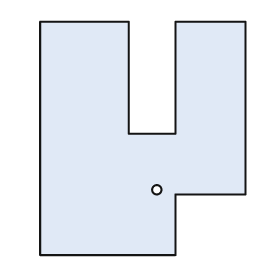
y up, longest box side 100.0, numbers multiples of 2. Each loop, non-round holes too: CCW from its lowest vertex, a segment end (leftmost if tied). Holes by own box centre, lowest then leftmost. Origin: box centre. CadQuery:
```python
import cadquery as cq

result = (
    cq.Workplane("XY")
    .moveTo(-44.0, -50.0)
    .lineTo(14.0, -50.0)
    .lineTo(14.0, -24.0)
    .lineTo(44.0, -24.0)
    .lineTo(44.0, 50.0)
    .lineTo(14.0, 50.0)
    .lineTo(14.0, 2.0)
    .lineTo(-6.0, 2.0)
    .lineTo(-6.0, 50.0)
    .lineTo(-44.0, 50.0)
    .close()
    .moveTo(6.0, -22.0)
    .circle(2.0)
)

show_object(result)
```